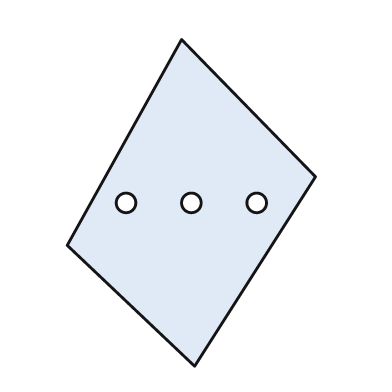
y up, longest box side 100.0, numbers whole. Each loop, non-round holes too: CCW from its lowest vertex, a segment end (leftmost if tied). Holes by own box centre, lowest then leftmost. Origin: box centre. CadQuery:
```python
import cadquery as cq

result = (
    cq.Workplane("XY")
    .moveTo(1.0, -50.0)
    .lineTo(38.0, 8.0)
    .lineTo(-3.0, 50.0)
    .lineTo(-38.0, -13.0)
    .close()
    .moveTo(-20.0, 0.0)
    .circle(3.0)
    .moveTo(0.0, 0.0)
    .circle(3.0)
    .moveTo(20.0, 0.0)
    .circle(3.0)
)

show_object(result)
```